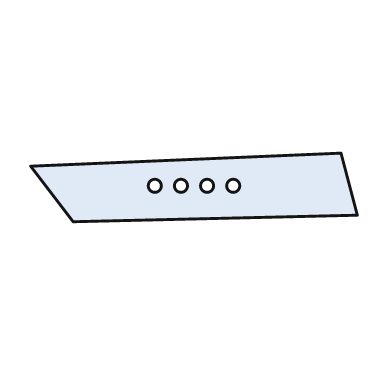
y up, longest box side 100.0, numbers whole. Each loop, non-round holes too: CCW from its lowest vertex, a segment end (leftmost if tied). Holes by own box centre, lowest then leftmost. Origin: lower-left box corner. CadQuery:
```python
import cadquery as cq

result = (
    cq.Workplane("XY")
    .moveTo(13.0, 0.0)
    .lineTo(100.0, 2.0)
    .lineTo(95.0, 21.0)
    .lineTo(0.0, 17.0)
    .close()
    .moveTo(38.0, 11.0)
    .circle(2.0)
    .moveTo(46.0, 11.0)
    .circle(2.0)
    .moveTo(54.0, 11.0)
    .circle(2.0)
    .moveTo(62.0, 11.0)
    .circle(2.0)
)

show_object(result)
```